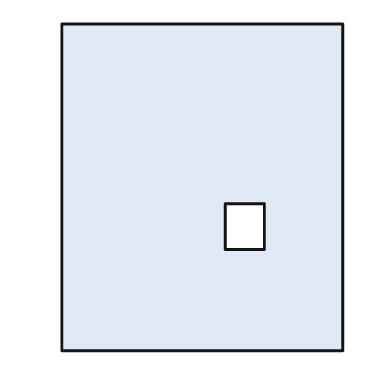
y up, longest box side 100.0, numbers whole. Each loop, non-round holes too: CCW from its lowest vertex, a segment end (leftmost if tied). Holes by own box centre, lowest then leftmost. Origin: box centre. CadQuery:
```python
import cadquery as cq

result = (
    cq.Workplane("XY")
    .moveTo(-43.0, -50.0)
    .lineTo(43.0, -50.0)
    .lineTo(43.0, 50.0)
    .lineTo(-43.0, 50.0)
    .close()
    .moveTo(7.0, -19.0)
    .lineTo(19.0, -19.0)
    .lineTo(19.0, -5.0)
    .lineTo(7.0, -5.0)
    .close()
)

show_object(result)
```